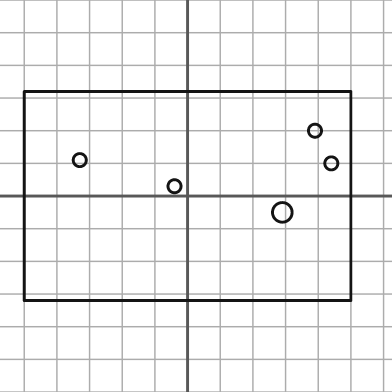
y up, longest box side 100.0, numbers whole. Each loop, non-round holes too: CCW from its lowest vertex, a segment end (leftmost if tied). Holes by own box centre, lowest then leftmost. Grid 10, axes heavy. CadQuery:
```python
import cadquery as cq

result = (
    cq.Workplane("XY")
    .moveTo(-50.0, -32.0)
    .lineTo(50.0, -32.0)
    .lineTo(50.0, 32.0)
    .lineTo(-50.0, 32.0)
    .close()
    .moveTo(29.0, -5.0)
    .circle(3.0)
    .moveTo(-4.0, 3.0)
    .circle(2.0)
    .moveTo(44.0, 10.0)
    .circle(2.0)
    .moveTo(-33.0, 11.0)
    .circle(2.0)
    .moveTo(39.0, 20.0)
    .circle(2.0)
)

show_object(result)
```